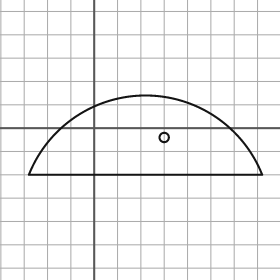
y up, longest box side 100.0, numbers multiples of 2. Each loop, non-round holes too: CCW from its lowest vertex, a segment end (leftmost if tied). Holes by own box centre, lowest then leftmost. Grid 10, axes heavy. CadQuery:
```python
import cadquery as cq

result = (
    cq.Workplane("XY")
    .moveTo(-28.0, -20.0)
    .lineTo(72.0, -20.0)
    .threePointArc((22.0, 14.0), (-28.0, -20.0))
    .close()
    .moveTo(30.0, -4.0)
    .circle(2.0)
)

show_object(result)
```